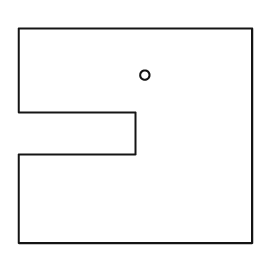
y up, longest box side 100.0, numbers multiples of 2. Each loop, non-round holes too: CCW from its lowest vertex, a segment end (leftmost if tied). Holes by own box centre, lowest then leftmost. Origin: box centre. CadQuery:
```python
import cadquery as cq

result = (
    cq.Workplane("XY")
    .moveTo(-50.0, -46.0)
    .lineTo(50.0, -46.0)
    .lineTo(50.0, 46.0)
    .lineTo(-50.0, 46.0)
    .lineTo(-50.0, 10.0)
    .lineTo(0.0, 10.0)
    .lineTo(0.0, -8.0)
    .lineTo(-50.0, -8.0)
    .close()
    .moveTo(4.0, 26.0)
    .circle(2.0)
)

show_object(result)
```